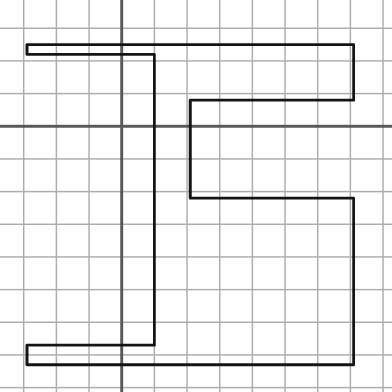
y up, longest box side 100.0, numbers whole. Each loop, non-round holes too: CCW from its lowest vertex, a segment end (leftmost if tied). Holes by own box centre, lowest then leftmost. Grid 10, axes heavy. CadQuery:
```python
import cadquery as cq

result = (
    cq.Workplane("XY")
    .moveTo(-29.0, -73.0)
    .lineTo(71.0, -73.0)
    .lineTo(71.0, -22.0)
    .lineTo(21.0, -22.0)
    .lineTo(21.0, 8.0)
    .lineTo(71.0, 8.0)
    .lineTo(71.0, 25.0)
    .lineTo(-29.0, 25.0)
    .lineTo(-29.0, 22.0)
    .lineTo(10.0, 22.0)
    .lineTo(10.0, -67.0)
    .lineTo(-29.0, -67.0)
    .close()
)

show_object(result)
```